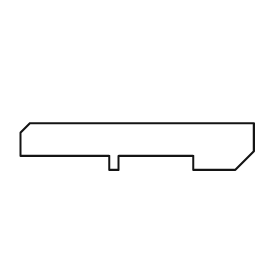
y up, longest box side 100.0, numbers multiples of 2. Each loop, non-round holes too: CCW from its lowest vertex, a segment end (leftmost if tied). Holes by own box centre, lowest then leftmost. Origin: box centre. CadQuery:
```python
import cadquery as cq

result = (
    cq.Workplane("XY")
    .moveTo(-12.0, -10.0)
    .lineTo(-8.0, -10.0)
    .lineTo(-8.0, -4.0)
    .lineTo(24.0, -4.0)
    .lineTo(24.0, -10.0)
    .lineTo(42.0, -10.0)
    .lineTo(50.0, -2.0)
    .lineTo(50.0, 10.0)
    .lineTo(-46.0, 10.0)
    .lineTo(-50.0, 6.0)
    .lineTo(-50.0, -4.0)
    .lineTo(-12.0, -4.0)
    .close()
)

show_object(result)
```